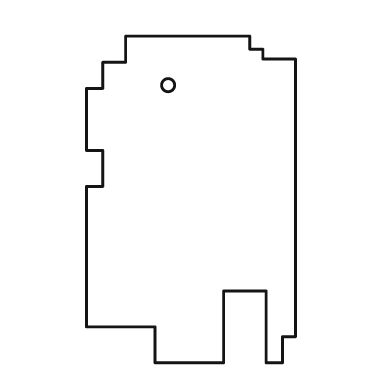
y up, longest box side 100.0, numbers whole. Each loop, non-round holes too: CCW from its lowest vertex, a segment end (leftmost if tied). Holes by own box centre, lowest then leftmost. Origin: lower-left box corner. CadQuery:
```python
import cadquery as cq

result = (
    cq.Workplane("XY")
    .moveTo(21.0, 0.0)
    .lineTo(42.0, 0.0)
    .lineTo(42.0, 22.0)
    .lineTo(55.0, 22.0)
    .lineTo(55.0, 0.0)
    .lineTo(60.0, 0.0)
    .lineTo(60.0, 8.0)
    .lineTo(64.0, 8.0)
    .lineTo(64.0, 93.0)
    .lineTo(54.0, 93.0)
    .lineTo(54.0, 96.0)
    .lineTo(50.0, 96.0)
    .lineTo(50.0, 100.0)
    .lineTo(12.0, 100.0)
    .lineTo(12.0, 92.0)
    .lineTo(5.0, 92.0)
    .lineTo(5.0, 84.0)
    .lineTo(0.0, 84.0)
    .lineTo(0.0, 65.0)
    .lineTo(5.0, 65.0)
    .lineTo(5.0, 54.0)
    .lineTo(0.0, 54.0)
    .lineTo(0.0, 11.0)
    .lineTo(21.0, 11.0)
    .close()
    .moveTo(25.0, 85.0)
    .circle(2.0)
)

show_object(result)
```